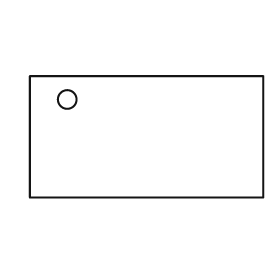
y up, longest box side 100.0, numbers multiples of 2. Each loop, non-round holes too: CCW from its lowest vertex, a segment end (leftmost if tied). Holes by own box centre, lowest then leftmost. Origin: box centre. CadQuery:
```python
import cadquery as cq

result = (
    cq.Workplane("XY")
    .moveTo(-50.0, -26.0)
    .lineTo(50.0, -26.0)
    .lineTo(50.0, 26.0)
    .lineTo(-50.0, 26.0)
    .close()
    .moveTo(-34.0, 16.0)
    .circle(4.0)
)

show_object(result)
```